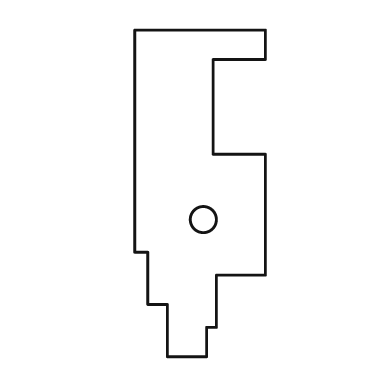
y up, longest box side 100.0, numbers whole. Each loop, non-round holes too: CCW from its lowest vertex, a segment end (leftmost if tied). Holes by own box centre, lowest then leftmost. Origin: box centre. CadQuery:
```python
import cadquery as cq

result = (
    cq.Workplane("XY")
    .moveTo(-10.0, -50.0)
    .lineTo(2.0, -50.0)
    .lineTo(2.0, -41.0)
    .lineTo(5.0, -41.0)
    .lineTo(5.0, -25.0)
    .lineTo(20.0, -25.0)
    .lineTo(20.0, 12.0)
    .lineTo(4.0, 12.0)
    .lineTo(4.0, 41.0)
    .lineTo(20.0, 41.0)
    .lineTo(20.0, 50.0)
    .lineTo(-20.0, 50.0)
    .lineTo(-20.0, -18.0)
    .lineTo(-16.0, -18.0)
    .lineTo(-16.0, -34.0)
    .lineTo(-10.0, -34.0)
    .close()
    .moveTo(1.0, -8.0)
    .circle(4.0)
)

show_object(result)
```